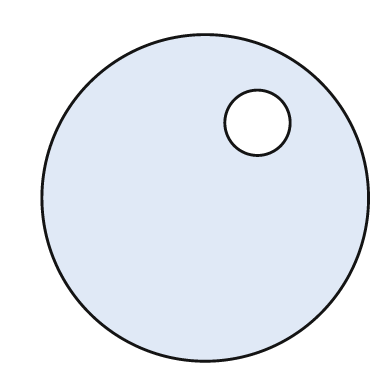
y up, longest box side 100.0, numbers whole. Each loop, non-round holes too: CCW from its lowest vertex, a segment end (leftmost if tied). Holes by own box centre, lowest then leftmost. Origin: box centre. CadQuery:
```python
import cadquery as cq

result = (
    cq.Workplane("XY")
    .moveTo(0.0, 0.0)
    .circle(50.0)
    .moveTo(16.0, 23.0)
    .circle(10.0)
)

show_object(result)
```